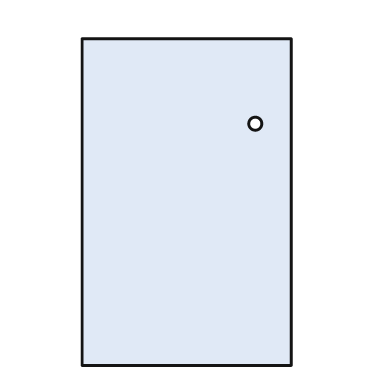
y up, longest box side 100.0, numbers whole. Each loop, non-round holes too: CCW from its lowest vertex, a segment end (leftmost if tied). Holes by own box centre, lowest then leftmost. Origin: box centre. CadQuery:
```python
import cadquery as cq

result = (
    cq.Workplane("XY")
    .moveTo(-32.0, -50.0)
    .lineTo(32.0, -50.0)
    .lineTo(32.0, 50.0)
    .lineTo(-32.0, 50.0)
    .close()
    .moveTo(21.0, 24.0)
    .circle(2.0)
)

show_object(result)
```